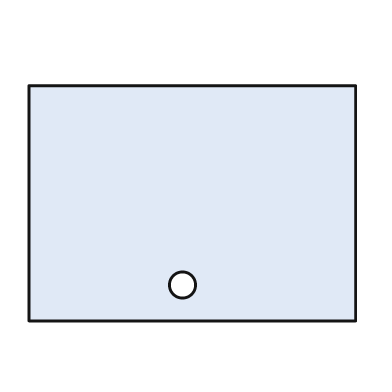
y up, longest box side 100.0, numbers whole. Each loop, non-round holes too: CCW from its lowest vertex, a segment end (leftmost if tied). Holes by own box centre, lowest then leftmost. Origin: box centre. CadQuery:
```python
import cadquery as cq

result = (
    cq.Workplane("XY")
    .moveTo(-50.0, -36.0)
    .lineTo(50.0, -36.0)
    .lineTo(50.0, 36.0)
    .lineTo(-50.0, 36.0)
    .close()
    .moveTo(-3.0, -25.0)
    .circle(4.0)
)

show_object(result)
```